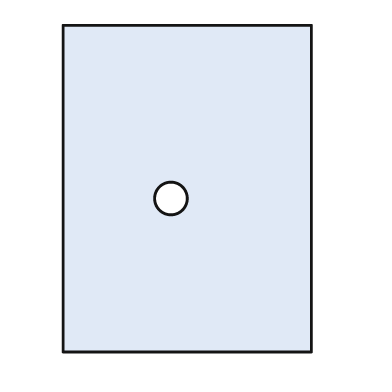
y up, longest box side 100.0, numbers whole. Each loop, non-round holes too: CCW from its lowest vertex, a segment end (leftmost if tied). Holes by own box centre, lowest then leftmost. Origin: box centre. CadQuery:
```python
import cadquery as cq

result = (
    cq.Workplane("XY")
    .moveTo(-38.0, -50.0)
    .lineTo(38.0, -50.0)
    .lineTo(38.0, 50.0)
    .lineTo(-38.0, 50.0)
    .close()
    .moveTo(-5.0, -3.0)
    .circle(5.0)
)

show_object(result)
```